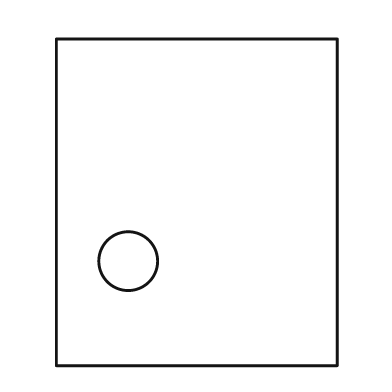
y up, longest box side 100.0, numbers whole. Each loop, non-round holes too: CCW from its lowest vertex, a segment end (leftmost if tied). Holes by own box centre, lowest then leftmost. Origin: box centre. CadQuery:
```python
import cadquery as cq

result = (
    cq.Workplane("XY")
    .moveTo(-43.0, -50.0)
    .lineTo(43.0, -50.0)
    .lineTo(43.0, 50.0)
    .lineTo(-43.0, 50.0)
    .close()
    .moveTo(-21.0, -18.0)
    .circle(9.0)
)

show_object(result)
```